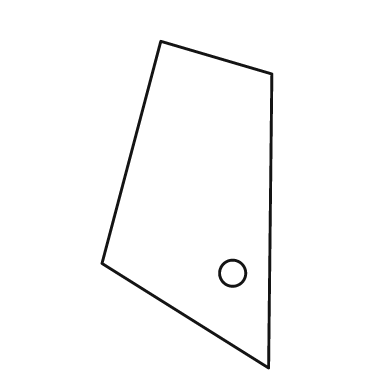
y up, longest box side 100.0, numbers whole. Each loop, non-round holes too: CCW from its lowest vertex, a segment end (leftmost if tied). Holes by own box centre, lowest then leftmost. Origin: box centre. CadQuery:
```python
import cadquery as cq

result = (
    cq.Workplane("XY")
    .moveTo(25.0, -50.0)
    .lineTo(26.0, 40.0)
    .lineTo(-8.0, 50.0)
    .lineTo(-26.0, -18.0)
    .close()
    .moveTo(14.0, -21.0)
    .circle(4.0)
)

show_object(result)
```